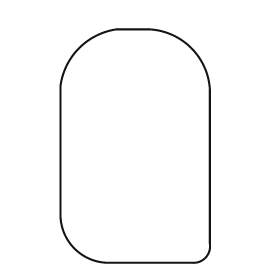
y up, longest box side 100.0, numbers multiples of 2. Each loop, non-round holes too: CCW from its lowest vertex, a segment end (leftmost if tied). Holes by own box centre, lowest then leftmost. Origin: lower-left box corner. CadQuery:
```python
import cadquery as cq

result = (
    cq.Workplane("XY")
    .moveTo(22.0, 0.0)
    .lineTo(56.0, 0.0)
    .threePointArc((62.0, 2.0), (64.0, 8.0))
    .lineTo(64.0, 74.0)
    .threePointArc((56.0, 92.0), (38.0, 100.0))
    .lineTo(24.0, 100.0)
    .threePointArc((8.0, 92.0), (0.0, 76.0))
    .lineTo(0.0, 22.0)
    .threePointArc((6.0, 6.0), (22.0, 0.0))
    .close()
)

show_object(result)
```